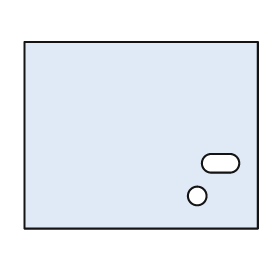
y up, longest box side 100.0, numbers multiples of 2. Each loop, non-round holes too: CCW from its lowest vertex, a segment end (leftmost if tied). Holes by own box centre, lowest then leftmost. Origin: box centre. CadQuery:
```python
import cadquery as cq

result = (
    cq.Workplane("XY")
    .moveTo(-50.0, -40.0)
    .lineTo(50.0, -40.0)
    .lineTo(50.0, 40.0)
    .lineTo(-50.0, 40.0)
    .close()
    .moveTo(24.0, -26.0)
    .circle(4.0)
    .moveTo(30.0, -16.0)
    .lineTo(38.0, -16.0)
    .threePointArc((42.0, -12.0), (38.0, -8.0))
    .lineTo(30.0, -8.0)
    .threePointArc((26.0, -12.0), (30.0, -16.0))
    .close()
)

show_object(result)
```